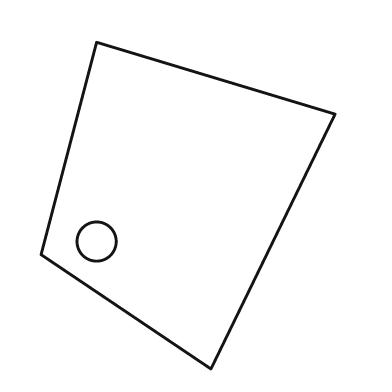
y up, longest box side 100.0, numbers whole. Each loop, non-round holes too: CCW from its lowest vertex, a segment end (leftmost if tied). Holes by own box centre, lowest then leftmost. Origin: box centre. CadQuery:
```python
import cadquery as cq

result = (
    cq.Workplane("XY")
    .moveTo(7.0, -50.0)
    .lineTo(45.0, 28.0)
    .lineTo(-28.0, 50.0)
    .lineTo(-45.0, -15.0)
    .close()
    .moveTo(-28.0, -11.0)
    .circle(6.0)
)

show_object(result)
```